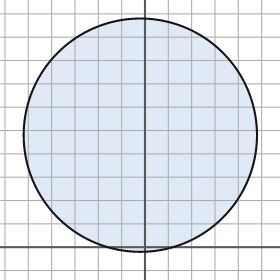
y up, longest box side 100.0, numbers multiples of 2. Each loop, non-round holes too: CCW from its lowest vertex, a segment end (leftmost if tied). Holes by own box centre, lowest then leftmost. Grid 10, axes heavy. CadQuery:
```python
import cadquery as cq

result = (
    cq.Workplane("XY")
    .moveTo(-2.0, 48.0)
    .circle(50.0)
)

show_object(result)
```